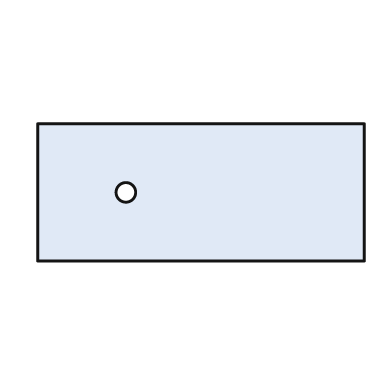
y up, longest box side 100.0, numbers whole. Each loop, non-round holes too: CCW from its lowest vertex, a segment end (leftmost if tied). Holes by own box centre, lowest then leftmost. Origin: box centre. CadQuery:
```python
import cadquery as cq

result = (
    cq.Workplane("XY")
    .moveTo(-50.0, -21.0)
    .lineTo(50.0, -21.0)
    .lineTo(50.0, 21.0)
    .lineTo(-50.0, 21.0)
    .close()
    .moveTo(-23.0, 0.0)
    .circle(3.0)
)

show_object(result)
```